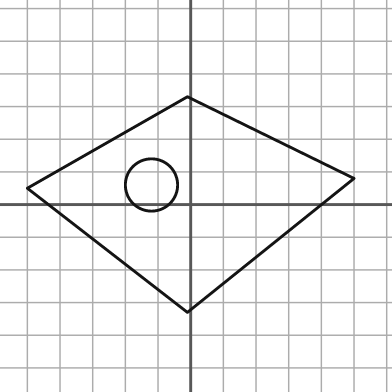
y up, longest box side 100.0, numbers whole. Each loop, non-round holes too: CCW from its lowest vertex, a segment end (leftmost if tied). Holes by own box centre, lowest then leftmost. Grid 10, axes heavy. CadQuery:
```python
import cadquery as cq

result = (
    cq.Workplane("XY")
    .moveTo(-1.0, -33.0)
    .lineTo(50.0, 8.0)
    .lineTo(-1.0, 33.0)
    .lineTo(-50.0, 5.0)
    .close()
    .moveTo(-12.0, 6.0)
    .circle(8.0)
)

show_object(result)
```